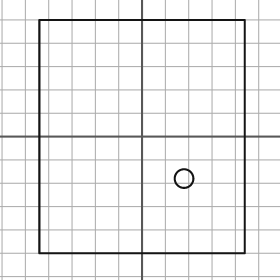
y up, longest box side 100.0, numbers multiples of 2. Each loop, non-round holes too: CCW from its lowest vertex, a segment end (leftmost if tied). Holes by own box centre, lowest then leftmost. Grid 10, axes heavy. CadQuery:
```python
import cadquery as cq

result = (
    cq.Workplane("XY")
    .moveTo(-44.0, -50.0)
    .lineTo(44.0, -50.0)
    .lineTo(44.0, 50.0)
    .lineTo(-44.0, 50.0)
    .close()
    .moveTo(18.0, -18.0)
    .circle(4.0)
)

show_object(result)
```